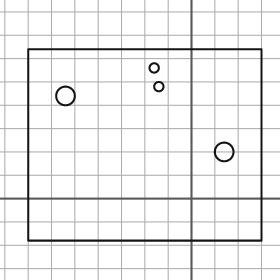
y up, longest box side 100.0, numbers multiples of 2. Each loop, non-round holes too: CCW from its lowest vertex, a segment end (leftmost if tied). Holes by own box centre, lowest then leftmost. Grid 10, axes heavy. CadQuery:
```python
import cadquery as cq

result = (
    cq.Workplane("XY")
    .moveTo(-70.0, -18.0)
    .lineTo(30.0, -18.0)
    .lineTo(30.0, 64.0)
    .lineTo(-70.0, 64.0)
    .close()
    .moveTo(14.0, 20.0)
    .circle(4.0)
    .moveTo(-54.0, 44.0)
    .circle(4.0)
    .moveTo(-14.0, 48.0)
    .circle(2.0)
    .moveTo(-16.0, 56.0)
    .circle(2.0)
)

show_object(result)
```